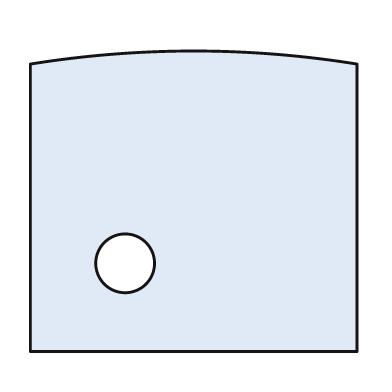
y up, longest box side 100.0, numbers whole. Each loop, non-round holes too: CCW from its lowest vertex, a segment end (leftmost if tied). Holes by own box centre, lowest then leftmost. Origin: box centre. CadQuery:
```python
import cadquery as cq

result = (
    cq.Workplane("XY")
    .moveTo(-50.0, -46.0)
    .lineTo(50.0, -46.0)
    .lineTo(50.0, 42.0)
    .threePointArc((0.0, 46.0), (-50.0, 42.0))
    .close()
    .moveTo(-21.0, -19.0)
    .circle(9.0)
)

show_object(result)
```